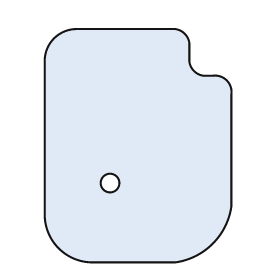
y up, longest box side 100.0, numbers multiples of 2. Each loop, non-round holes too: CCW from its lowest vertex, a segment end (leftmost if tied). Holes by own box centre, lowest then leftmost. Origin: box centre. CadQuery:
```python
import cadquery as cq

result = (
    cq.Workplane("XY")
    .moveTo(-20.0, -50.0)
    .lineTo(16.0, -50.0)
    .threePointArc((32.0, -42.0), (40.0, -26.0))
    .lineTo(40.0, 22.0)
    .threePointArc((38.0, 28.0), (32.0, 30.0))
    .lineTo(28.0, 30.0)
    .threePointArc((24.0, 32.0), (22.0, 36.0))
    .lineTo(22.0, 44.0)
    .threePointArc((20.0, 48.0), (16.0, 50.0))
    .lineTo(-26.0, 50.0)
    .threePointArc((-36.0, 46.0), (-40.0, 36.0))
    .lineTo(-40.0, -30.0)
    .threePointArc((-34.0, -44.0), (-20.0, -50.0))
    .close()
    .moveTo(-12.0, -16.0)
    .circle(4.0)
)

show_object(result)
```